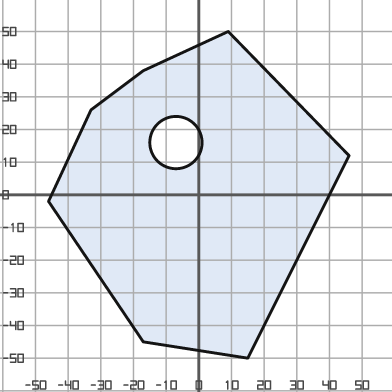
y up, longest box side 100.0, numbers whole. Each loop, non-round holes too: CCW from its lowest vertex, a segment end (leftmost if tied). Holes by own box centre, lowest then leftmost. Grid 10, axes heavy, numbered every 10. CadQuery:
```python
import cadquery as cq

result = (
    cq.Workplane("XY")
    .moveTo(15.0, -50.0)
    .lineTo(46.0, 12.0)
    .lineTo(9.0, 50.0)
    .lineTo(-17.0, 38.0)
    .lineTo(-33.0, 26.0)
    .lineTo(-46.0, -2.0)
    .lineTo(-17.0, -45.0)
    .close()
    .moveTo(-7.0, 16.0)
    .circle(8.0)
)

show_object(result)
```